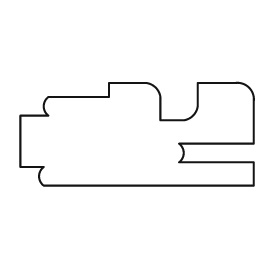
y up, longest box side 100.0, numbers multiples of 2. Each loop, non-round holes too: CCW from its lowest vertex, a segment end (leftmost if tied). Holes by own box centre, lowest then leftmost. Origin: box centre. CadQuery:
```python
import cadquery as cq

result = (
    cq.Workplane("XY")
    .moveTo(-40.0, -22.0)
    .lineTo(50.0, -22.0)
    .lineTo(50.0, -12.0)
    .lineTo(18.0, -12.0)
    .threePointArc((20.0, -8.0), (18.0, -4.0))
    .lineTo(50.0, -4.0)
    .lineTo(50.0, 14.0)
    .threePointArc((48.0, 20.0), (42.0, 22.0))
    .lineTo(26.0, 22.0)
    .lineTo(26.0, 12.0)
    .threePointArc((24.0, 8.0), (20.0, 6.0))
    .lineTo(10.0, 6.0)
    .lineTo(10.0, 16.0)
    .threePointArc((8.0, 20.0), (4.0, 22.0))
    .lineTo(-12.0, 22.0)
    .lineTo(-12.0, 16.0)
    .lineTo(-38.0, 16.0)
    .threePointArc((-40.0, 12.0), (-38.0, 8.0))
    .lineTo(-50.0, 8.0)
    .lineTo(-50.0, -14.0)
    .lineTo(-40.0, -14.0)
    .threePointArc((-42.0, -18.0), (-40.0, -22.0))
    .close()
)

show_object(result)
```